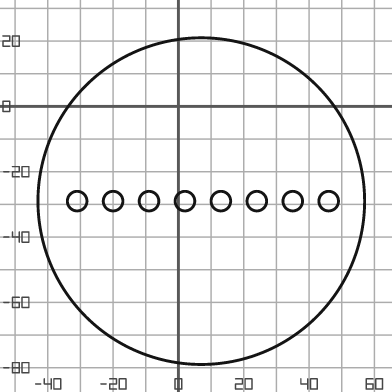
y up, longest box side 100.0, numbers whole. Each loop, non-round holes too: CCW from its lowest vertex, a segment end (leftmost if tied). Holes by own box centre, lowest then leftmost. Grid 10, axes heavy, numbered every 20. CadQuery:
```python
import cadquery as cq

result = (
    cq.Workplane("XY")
    .moveTo(7.0, -29.0)
    .circle(50.0)
    .moveTo(-31.0, -29.0)
    .circle(3.0)
    .moveTo(-20.0, -29.0)
    .circle(3.0)
    .moveTo(-9.0, -29.0)
    .circle(3.0)
    .moveTo(2.0, -29.0)
    .circle(3.0)
    .moveTo(13.0, -29.0)
    .circle(3.0)
    .moveTo(24.0, -29.0)
    .circle(3.0)
    .moveTo(35.0, -29.0)
    .circle(3.0)
    .moveTo(46.0, -29.0)
    .circle(3.0)
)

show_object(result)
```